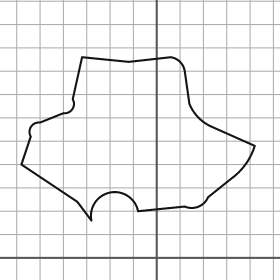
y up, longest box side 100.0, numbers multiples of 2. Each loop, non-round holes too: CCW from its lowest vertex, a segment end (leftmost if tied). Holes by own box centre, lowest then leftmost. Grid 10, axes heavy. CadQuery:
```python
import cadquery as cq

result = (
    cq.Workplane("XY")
    .moveTo(-28.0, 16.0)
    .threePointArc((-20.0, 28.0), (-8.0, 20.0))
    .lineTo(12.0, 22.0)
    .threePointArc((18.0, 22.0), (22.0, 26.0))
    .lineTo(32.0, 34.0)
    .threePointArc((38.0, 40.0), (42.0, 48.0))
    .lineTo(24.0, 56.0)
    .threePointArc((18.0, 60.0), (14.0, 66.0))
    .lineTo(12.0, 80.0)
    .threePointArc((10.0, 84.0), (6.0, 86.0))
    .lineTo(-12.0, 84.0)
    .lineTo(-32.0, 86.0)
    .lineTo(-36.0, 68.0)
    .threePointArc((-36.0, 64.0), (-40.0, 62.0))
    .lineTo(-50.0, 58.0)
    .threePointArc((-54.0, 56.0), (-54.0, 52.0))
    .lineTo(-58.0, 40.0)
    .lineTo(-34.0, 24.0)
    .close()
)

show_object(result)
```